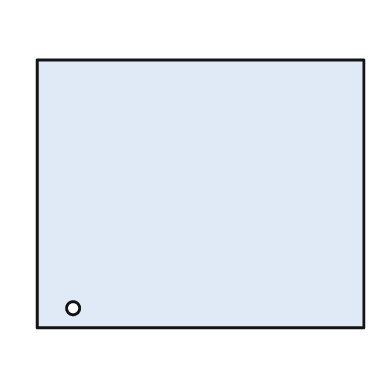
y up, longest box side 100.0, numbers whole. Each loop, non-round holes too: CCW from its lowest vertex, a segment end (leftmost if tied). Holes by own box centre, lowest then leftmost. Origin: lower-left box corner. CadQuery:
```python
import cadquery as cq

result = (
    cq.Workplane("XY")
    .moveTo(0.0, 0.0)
    .lineTo(100.0, 0.0)
    .lineTo(100.0, 82.0)
    .lineTo(0.0, 82.0)
    .close()
    .moveTo(11.0, 6.0)
    .circle(2.0)
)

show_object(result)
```